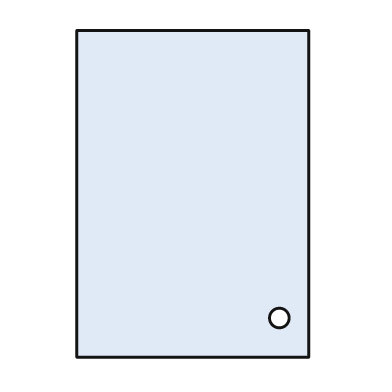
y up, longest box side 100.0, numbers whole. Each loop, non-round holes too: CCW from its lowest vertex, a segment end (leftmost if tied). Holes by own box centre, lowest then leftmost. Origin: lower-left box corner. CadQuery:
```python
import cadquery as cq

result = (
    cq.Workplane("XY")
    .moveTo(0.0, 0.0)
    .lineTo(71.0, 0.0)
    .lineTo(71.0, 100.0)
    .lineTo(0.0, 100.0)
    .close()
    .moveTo(62.0, 12.0)
    .circle(3.0)
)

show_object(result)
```